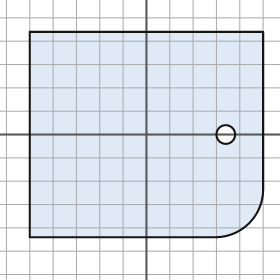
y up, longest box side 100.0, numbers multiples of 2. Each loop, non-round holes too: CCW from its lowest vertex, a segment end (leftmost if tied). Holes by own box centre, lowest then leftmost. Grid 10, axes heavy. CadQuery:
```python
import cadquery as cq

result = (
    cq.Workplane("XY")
    .moveTo(-50.0, -44.0)
    .lineTo(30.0, -44.0)
    .threePointArc((44.0, -38.0), (50.0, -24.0))
    .lineTo(50.0, 44.0)
    .lineTo(-50.0, 44.0)
    .close()
    .moveTo(34.0, 0.0)
    .circle(4.0)
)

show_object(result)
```